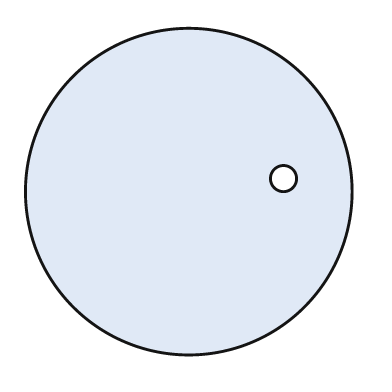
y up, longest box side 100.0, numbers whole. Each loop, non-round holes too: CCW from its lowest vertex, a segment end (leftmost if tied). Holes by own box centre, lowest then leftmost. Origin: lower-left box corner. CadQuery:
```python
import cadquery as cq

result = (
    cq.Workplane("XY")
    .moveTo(50.0, 50.0)
    .circle(50.0)
    .moveTo(79.0, 54.0)
    .circle(4.0)
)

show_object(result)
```